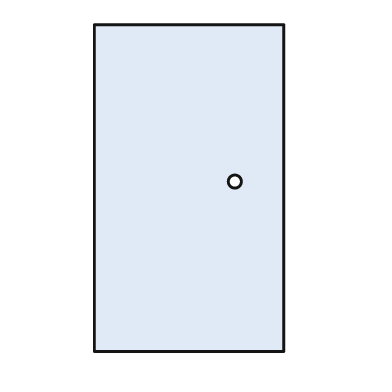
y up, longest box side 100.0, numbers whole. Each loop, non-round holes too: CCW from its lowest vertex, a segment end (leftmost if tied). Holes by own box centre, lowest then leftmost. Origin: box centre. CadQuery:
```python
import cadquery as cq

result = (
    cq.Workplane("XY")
    .moveTo(-29.0, -50.0)
    .lineTo(29.0, -50.0)
    .lineTo(29.0, 50.0)
    .lineTo(-29.0, 50.0)
    .close()
    .moveTo(14.0, 2.0)
    .circle(2.0)
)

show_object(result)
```